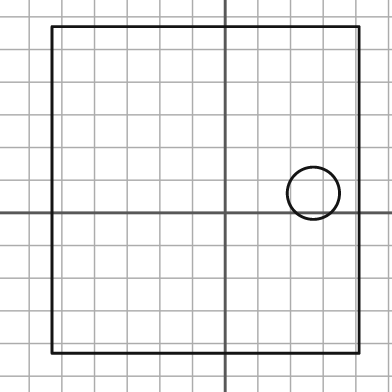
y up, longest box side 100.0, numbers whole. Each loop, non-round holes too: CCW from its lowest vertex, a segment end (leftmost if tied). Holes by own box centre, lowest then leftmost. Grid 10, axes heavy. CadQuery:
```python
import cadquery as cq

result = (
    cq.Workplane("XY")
    .moveTo(-53.0, -43.0)
    .lineTo(41.0, -43.0)
    .lineTo(41.0, 57.0)
    .lineTo(-53.0, 57.0)
    .close()
    .moveTo(27.0, 6.0)
    .circle(8.0)
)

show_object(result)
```